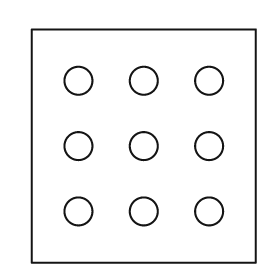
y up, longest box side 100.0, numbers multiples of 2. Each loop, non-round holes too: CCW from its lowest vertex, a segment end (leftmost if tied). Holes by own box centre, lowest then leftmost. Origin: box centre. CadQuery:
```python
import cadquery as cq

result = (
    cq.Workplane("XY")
    .moveTo(-48.0, -50.0)
    .lineTo(48.0, -50.0)
    .lineTo(48.0, 50.0)
    .lineTo(-48.0, 50.0)
    .close()
    .moveTo(-28.0, -28.0)
    .circle(6.0)
    .moveTo(0.0, -28.0)
    .circle(6.0)
    .moveTo(28.0, -28.0)
    .circle(6.0)
    .moveTo(-28.0, 0.0)
    .circle(6.0)
    .moveTo(0.0, 0.0)
    .circle(6.0)
    .moveTo(28.0, 0.0)
    .circle(6.0)
    .moveTo(-28.0, 28.0)
    .circle(6.0)
    .moveTo(0.0, 28.0)
    .circle(6.0)
    .moveTo(28.0, 28.0)
    .circle(6.0)
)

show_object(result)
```